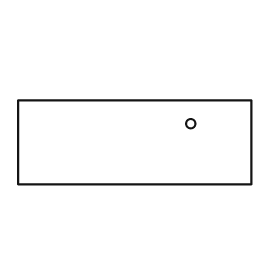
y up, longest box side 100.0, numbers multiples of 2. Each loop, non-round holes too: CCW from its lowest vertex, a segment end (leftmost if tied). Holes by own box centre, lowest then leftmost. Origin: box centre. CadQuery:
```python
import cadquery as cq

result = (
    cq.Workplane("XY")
    .moveTo(-50.0, -18.0)
    .lineTo(50.0, -18.0)
    .lineTo(50.0, 18.0)
    .lineTo(-50.0, 18.0)
    .close()
    .moveTo(24.0, 8.0)
    .circle(2.0)
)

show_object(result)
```